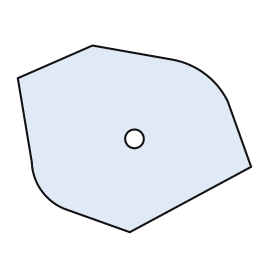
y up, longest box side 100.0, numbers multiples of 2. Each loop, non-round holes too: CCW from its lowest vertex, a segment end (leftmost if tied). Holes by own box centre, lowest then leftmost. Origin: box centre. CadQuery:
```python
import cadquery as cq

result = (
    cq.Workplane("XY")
    .moveTo(-2.0, -40.0)
    .lineTo(50.0, -12.0)
    .lineTo(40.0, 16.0)
    .threePointArc((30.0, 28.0), (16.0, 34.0))
    .lineTo(-18.0, 40.0)
    .lineTo(-50.0, 26.0)
    .lineTo(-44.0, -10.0)
    .threePointArc((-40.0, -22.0), (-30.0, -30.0))
    .close()
    .moveTo(0.0, 0.0)
    .circle(4.0)
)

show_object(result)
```